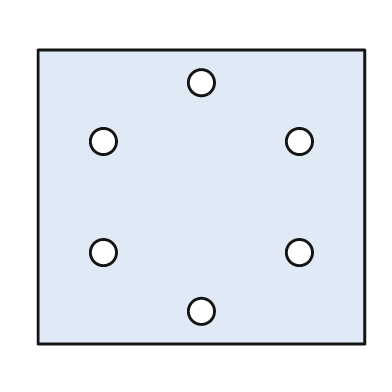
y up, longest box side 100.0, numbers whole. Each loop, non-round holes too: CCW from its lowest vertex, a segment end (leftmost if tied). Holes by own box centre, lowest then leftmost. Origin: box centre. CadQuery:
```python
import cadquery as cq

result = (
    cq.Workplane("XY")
    .moveTo(-50.0, -45.0)
    .lineTo(50.0, -45.0)
    .lineTo(50.0, 45.0)
    .lineTo(-50.0, 45.0)
    .close()
    .moveTo(0.0, -35.0)
    .circle(4.0)
    .moveTo(-30.0, -17.0)
    .circle(4.0)
    .moveTo(30.0, -17.0)
    .circle(4.0)
    .moveTo(-30.0, 17.0)
    .circle(4.0)
    .moveTo(30.0, 17.0)
    .circle(4.0)
    .moveTo(0.0, 35.0)
    .circle(4.0)
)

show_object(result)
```